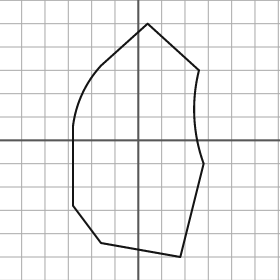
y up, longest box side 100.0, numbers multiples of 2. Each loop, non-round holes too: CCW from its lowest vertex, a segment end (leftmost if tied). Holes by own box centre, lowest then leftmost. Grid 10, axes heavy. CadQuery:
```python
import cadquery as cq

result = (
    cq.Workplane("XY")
    .moveTo(18.0, -50.0)
    .lineTo(28.0, -10.0)
    .threePointArc((24.0, 10.0), (26.0, 30.0))
    .lineTo(4.0, 50.0)
    .lineTo(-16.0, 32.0)
    .threePointArc((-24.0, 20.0), (-28.0, 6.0))
    .lineTo(-28.0, -28.0)
    .lineTo(-16.0, -44.0)
    .close()
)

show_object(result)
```